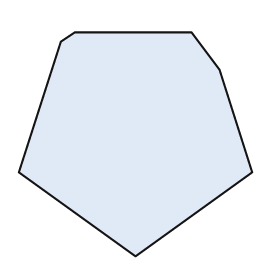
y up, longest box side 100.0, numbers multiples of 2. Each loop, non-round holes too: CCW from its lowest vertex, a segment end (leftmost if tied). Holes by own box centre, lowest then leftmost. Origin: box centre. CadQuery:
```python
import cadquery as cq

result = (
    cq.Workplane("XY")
    .moveTo(0.0, -48.0)
    .lineTo(50.0, -12.0)
    .lineTo(36.0, 32.0)
    .lineTo(24.0, 48.0)
    .lineTo(-26.0, 48.0)
    .lineTo(-32.0, 44.0)
    .lineTo(-50.0, -12.0)
    .close()
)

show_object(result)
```